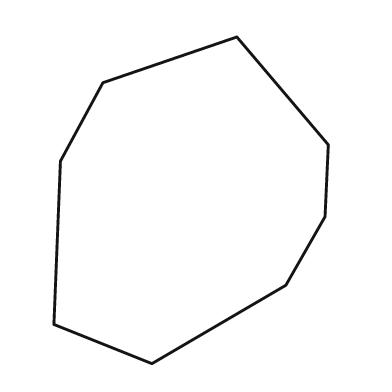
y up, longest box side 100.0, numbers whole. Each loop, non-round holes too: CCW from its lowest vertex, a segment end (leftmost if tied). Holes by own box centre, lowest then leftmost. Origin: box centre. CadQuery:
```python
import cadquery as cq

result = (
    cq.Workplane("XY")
    .moveTo(-12.0, -50.0)
    .lineTo(29.0, -26.0)
    .lineTo(41.0, -5.0)
    .lineTo(42.0, 17.0)
    .lineTo(14.0, 50.0)
    .lineTo(-27.0, 36.0)
    .lineTo(-40.0, 12.0)
    .lineTo(-42.0, -38.0)
    .close()
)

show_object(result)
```